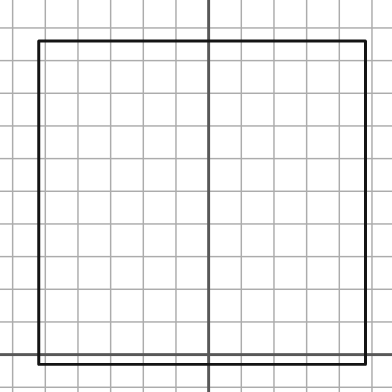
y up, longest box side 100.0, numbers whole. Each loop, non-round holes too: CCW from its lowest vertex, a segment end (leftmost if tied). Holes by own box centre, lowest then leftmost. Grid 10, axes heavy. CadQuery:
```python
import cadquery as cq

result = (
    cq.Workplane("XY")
    .moveTo(-52.0, -3.0)
    .lineTo(48.0, -3.0)
    .lineTo(48.0, 96.0)
    .lineTo(-52.0, 96.0)
    .close()
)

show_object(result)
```